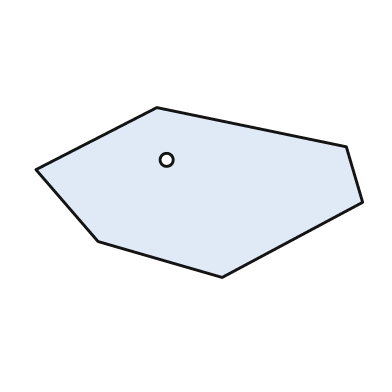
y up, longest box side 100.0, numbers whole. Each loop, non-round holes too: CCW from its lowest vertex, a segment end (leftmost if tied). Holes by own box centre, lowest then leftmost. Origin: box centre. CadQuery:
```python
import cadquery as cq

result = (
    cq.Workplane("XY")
    .moveTo(7.0, -26.0)
    .lineTo(50.0, -3.0)
    .lineTo(45.0, 14.0)
    .lineTo(-13.0, 26.0)
    .lineTo(-50.0, 7.0)
    .lineTo(-31.0, -15.0)
    .close()
    .moveTo(-10.0, 10.0)
    .circle(2.0)
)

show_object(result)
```